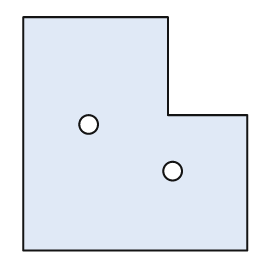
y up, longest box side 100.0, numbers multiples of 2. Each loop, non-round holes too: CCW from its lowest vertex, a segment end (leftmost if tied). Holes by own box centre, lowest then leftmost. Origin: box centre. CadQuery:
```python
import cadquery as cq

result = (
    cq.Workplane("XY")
    .moveTo(-48.0, -50.0)
    .lineTo(48.0, -50.0)
    .lineTo(48.0, 8.0)
    .lineTo(14.0, 8.0)
    .lineTo(14.0, 50.0)
    .lineTo(-48.0, 50.0)
    .close()
    .moveTo(16.0, -16.0)
    .circle(4.0)
    .moveTo(-20.0, 4.0)
    .circle(4.0)
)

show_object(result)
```